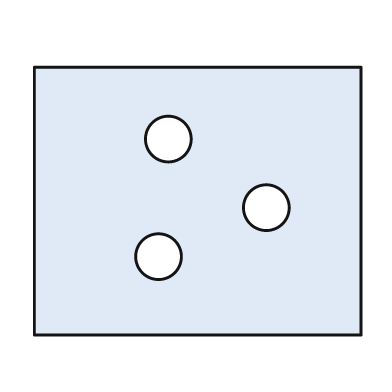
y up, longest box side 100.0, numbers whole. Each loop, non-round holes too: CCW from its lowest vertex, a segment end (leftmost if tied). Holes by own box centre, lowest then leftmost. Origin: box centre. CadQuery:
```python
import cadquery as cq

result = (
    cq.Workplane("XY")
    .moveTo(-50.0, -41.0)
    .lineTo(50.0, -41.0)
    .lineTo(50.0, 41.0)
    .lineTo(-50.0, 41.0)
    .close()
    .moveTo(-12.0, -17.0)
    .circle(7.0)
    .moveTo(21.0, -2.0)
    .circle(7.0)
    .moveTo(-9.0, 19.0)
    .circle(7.0)
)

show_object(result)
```